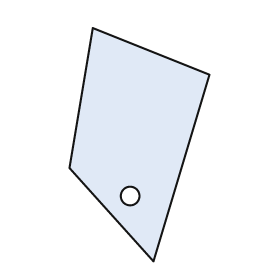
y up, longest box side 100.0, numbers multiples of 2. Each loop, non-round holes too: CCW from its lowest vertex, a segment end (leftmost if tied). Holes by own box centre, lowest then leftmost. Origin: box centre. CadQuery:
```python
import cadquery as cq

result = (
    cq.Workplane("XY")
    .moveTo(6.0, -50.0)
    .lineTo(30.0, 30.0)
    .lineTo(-20.0, 50.0)
    .lineTo(-30.0, -10.0)
    .close()
    .moveTo(-4.0, -22.0)
    .circle(4.0)
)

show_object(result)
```